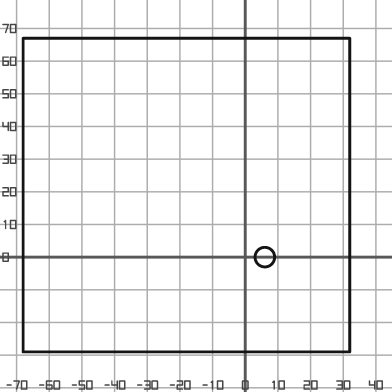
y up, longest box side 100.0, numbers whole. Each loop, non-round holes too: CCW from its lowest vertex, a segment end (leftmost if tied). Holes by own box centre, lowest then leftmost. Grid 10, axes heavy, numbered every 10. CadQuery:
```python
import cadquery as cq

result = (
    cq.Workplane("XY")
    .moveTo(-68.0, -29.0)
    .lineTo(32.0, -29.0)
    .lineTo(32.0, 67.0)
    .lineTo(-68.0, 67.0)
    .close()
    .moveTo(6.0, 0.0)
    .circle(3.0)
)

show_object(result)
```